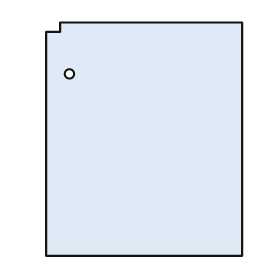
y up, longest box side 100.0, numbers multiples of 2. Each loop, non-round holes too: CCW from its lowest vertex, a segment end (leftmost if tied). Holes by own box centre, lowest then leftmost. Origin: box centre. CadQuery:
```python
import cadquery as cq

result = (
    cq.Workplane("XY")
    .moveTo(-42.0, -50.0)
    .lineTo(42.0, -50.0)
    .lineTo(42.0, 50.0)
    .lineTo(-36.0, 50.0)
    .lineTo(-36.0, 46.0)
    .lineTo(-42.0, 46.0)
    .close()
    .moveTo(-32.0, 28.0)
    .circle(2.0)
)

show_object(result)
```